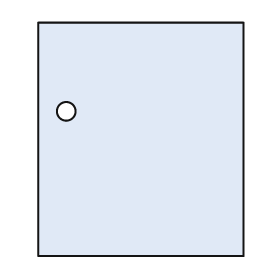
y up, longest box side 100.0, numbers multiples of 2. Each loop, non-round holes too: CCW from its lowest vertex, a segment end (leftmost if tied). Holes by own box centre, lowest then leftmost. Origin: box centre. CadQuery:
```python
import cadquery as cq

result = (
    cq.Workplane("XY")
    .moveTo(-44.0, -50.0)
    .lineTo(44.0, -50.0)
    .lineTo(44.0, 50.0)
    .lineTo(-44.0, 50.0)
    .close()
    .moveTo(-32.0, 12.0)
    .circle(4.0)
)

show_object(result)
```